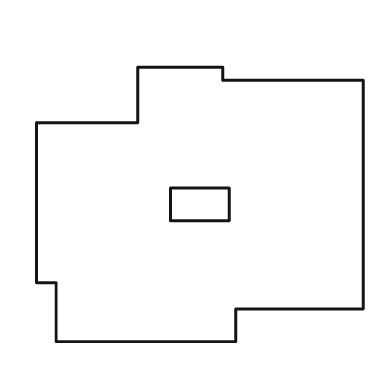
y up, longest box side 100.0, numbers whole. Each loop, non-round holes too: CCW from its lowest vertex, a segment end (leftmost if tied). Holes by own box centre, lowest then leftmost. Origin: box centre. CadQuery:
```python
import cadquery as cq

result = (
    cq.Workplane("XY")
    .moveTo(-44.0, -42.0)
    .lineTo(11.0, -42.0)
    .lineTo(11.0, -32.0)
    .lineTo(50.0, -32.0)
    .lineTo(50.0, 38.0)
    .lineTo(7.0, 38.0)
    .lineTo(7.0, 42.0)
    .lineTo(-19.0, 42.0)
    .lineTo(-19.0, 25.0)
    .lineTo(-50.0, 25.0)
    .lineTo(-50.0, -24.0)
    .lineTo(-44.0, -24.0)
    .close()
    .moveTo(-9.0, -5.0)
    .lineTo(9.0, -5.0)
    .lineTo(9.0, 5.0)
    .lineTo(-9.0, 5.0)
    .close()
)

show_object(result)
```